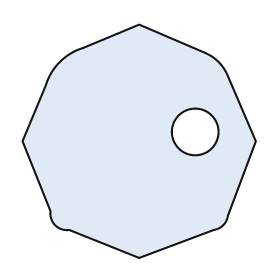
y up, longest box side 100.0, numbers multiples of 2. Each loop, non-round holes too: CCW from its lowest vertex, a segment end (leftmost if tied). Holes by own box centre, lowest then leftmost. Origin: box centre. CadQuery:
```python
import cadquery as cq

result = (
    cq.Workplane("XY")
    .moveTo(0.0, -50.0)
    .lineTo(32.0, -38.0)
    .threePointArc((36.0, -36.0), (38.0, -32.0))
    .lineTo(50.0, 0.0)
    .lineTo(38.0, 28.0)
    .threePointArc((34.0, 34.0), (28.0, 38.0))
    .lineTo(0.0, 50.0)
    .lineTo(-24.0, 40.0)
    .threePointArc((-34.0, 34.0), (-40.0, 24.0))
    .lineTo(-50.0, 0.0)
    .lineTo(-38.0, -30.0)
    .threePointArc((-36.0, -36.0), (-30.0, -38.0))
    .close()
    .moveTo(24.0, 4.0)
    .circle(10.0)
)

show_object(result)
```